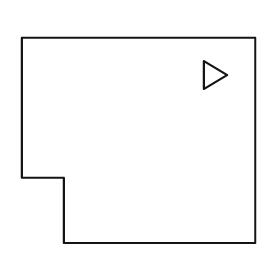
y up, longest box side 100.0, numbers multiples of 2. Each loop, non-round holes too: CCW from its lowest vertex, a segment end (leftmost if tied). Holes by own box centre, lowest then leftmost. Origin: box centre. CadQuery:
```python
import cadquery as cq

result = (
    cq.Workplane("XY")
    .moveTo(-32.0, -44.0)
    .lineTo(50.0, -44.0)
    .lineTo(50.0, 44.0)
    .lineTo(-50.0, 44.0)
    .lineTo(-50.0, -16.0)
    .lineTo(-32.0, -16.0)
    .close()
    .moveTo(28.0, 22.0)
    .lineTo(38.0, 28.0)
    .lineTo(28.0, 34.0)
    .close()
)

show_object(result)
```